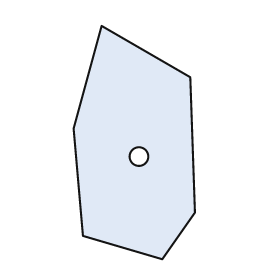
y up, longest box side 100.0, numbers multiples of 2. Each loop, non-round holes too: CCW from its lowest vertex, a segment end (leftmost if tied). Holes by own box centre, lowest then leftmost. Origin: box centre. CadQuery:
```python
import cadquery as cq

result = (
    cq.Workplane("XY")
    .moveTo(12.0, -50.0)
    .lineTo(26.0, -30.0)
    .lineTo(24.0, 28.0)
    .lineTo(-14.0, 50.0)
    .lineTo(-26.0, 6.0)
    .lineTo(-22.0, -40.0)
    .close()
    .moveTo(2.0, -6.0)
    .circle(4.0)
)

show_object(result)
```